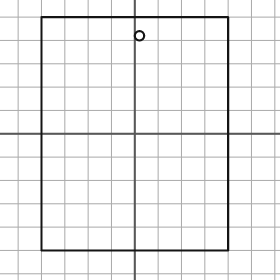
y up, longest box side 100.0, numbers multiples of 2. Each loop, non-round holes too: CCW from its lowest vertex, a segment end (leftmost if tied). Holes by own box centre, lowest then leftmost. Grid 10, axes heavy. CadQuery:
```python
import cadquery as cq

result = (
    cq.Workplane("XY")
    .moveTo(-40.0, -50.0)
    .lineTo(40.0, -50.0)
    .lineTo(40.0, 50.0)
    .lineTo(-40.0, 50.0)
    .close()
    .moveTo(2.0, 42.0)
    .circle(2.0)
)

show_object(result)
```